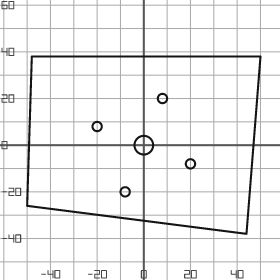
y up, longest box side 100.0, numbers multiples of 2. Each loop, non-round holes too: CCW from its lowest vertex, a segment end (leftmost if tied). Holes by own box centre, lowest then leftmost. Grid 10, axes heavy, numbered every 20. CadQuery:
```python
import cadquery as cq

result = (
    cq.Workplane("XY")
    .moveTo(44.0, -38.0)
    .lineTo(50.0, 38.0)
    .lineTo(-48.0, 38.0)
    .lineTo(-50.0, -26.0)
    .close()
    .moveTo(-8.0, -20.0)
    .circle(2.0)
    .moveTo(20.0, -8.0)
    .circle(2.0)
    .moveTo(0.0, 0.0)
    .circle(4.0)
    .moveTo(-20.0, 8.0)
    .circle(2.0)
    .moveTo(8.0, 20.0)
    .circle(2.0)
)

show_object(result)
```